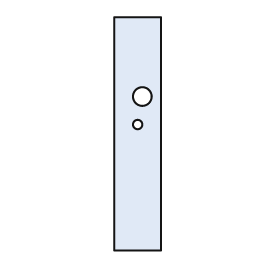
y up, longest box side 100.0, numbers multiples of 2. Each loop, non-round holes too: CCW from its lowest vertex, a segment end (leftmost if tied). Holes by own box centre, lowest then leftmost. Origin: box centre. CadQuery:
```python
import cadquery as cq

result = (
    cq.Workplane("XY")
    .moveTo(-10.0, -50.0)
    .lineTo(10.0, -50.0)
    .lineTo(10.0, 50.0)
    .lineTo(-10.0, 50.0)
    .close()
    .moveTo(0.0, 4.0)
    .circle(2.0)
    .moveTo(2.0, 16.0)
    .circle(4.0)
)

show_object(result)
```